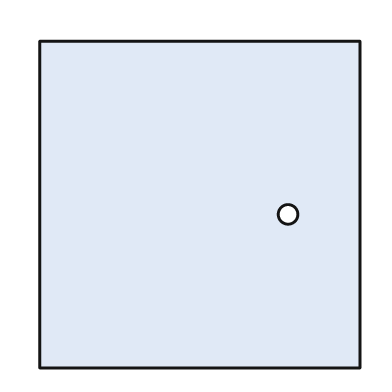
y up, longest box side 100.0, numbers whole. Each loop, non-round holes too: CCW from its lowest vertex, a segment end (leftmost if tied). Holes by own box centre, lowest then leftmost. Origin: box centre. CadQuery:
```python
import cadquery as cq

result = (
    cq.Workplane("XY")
    .moveTo(-49.0, -50.0)
    .lineTo(49.0, -50.0)
    .lineTo(49.0, 50.0)
    .lineTo(-49.0, 50.0)
    .close()
    .moveTo(27.0, -3.0)
    .circle(3.0)
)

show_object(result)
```